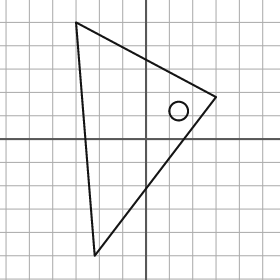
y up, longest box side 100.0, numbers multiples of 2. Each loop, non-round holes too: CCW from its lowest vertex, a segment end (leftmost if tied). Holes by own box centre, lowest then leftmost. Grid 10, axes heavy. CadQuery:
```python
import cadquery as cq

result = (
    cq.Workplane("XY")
    .moveTo(-22.0, -50.0)
    .lineTo(30.0, 18.0)
    .lineTo(-30.0, 50.0)
    .close()
    .moveTo(14.0, 12.0)
    .circle(4.0)
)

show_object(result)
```